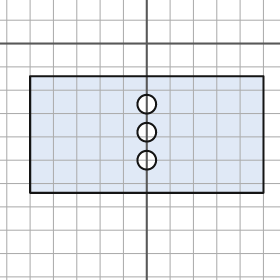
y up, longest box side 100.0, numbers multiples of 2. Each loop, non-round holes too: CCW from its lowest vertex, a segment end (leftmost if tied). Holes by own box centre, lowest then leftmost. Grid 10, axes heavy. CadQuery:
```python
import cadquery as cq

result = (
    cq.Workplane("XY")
    .moveTo(-50.0, -64.0)
    .lineTo(50.0, -64.0)
    .lineTo(50.0, -14.0)
    .lineTo(-50.0, -14.0)
    .close()
    .moveTo(0.0, -50.0)
    .circle(4.0)
    .moveTo(0.0, -38.0)
    .circle(4.0)
    .moveTo(0.0, -26.0)
    .circle(4.0)
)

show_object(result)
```